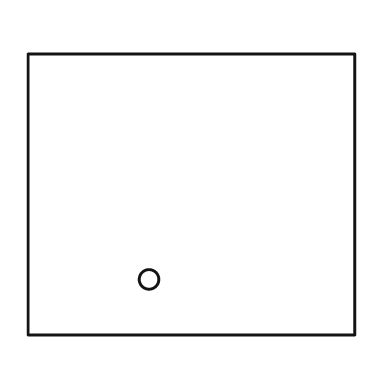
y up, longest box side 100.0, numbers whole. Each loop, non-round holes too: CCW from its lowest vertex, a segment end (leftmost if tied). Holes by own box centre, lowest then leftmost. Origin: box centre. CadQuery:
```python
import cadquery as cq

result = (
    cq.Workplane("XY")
    .moveTo(-50.0, -43.0)
    .lineTo(50.0, -43.0)
    .lineTo(50.0, 43.0)
    .lineTo(-50.0, 43.0)
    .close()
    .moveTo(-13.0, -26.0)
    .circle(3.0)
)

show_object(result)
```